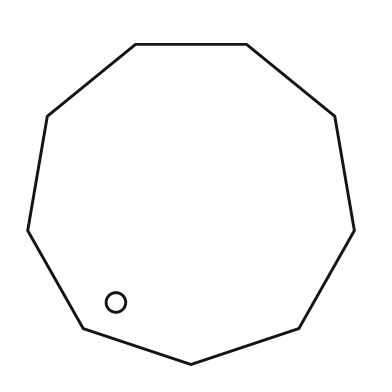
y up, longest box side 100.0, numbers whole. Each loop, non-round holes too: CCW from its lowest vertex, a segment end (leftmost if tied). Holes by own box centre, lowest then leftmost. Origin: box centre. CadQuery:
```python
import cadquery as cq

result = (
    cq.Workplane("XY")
    .moveTo(0.0, -49.0)
    .lineTo(33.0, -38.0)
    .lineTo(50.0, -8.0)
    .lineTo(44.0, 27.0)
    .lineTo(17.0, 49.0)
    .lineTo(-17.0, 49.0)
    .lineTo(-44.0, 27.0)
    .lineTo(-50.0, -8.0)
    .lineTo(-33.0, -38.0)
    .close()
    .moveTo(-23.0, -30.0)
    .circle(3.0)
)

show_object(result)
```